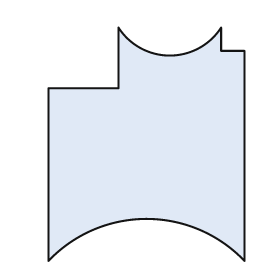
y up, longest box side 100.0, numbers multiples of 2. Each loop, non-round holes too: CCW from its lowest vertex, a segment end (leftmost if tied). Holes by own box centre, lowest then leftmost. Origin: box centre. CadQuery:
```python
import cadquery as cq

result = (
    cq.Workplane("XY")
    .moveTo(-42.0, -50.0)
    .threePointArc((0.0, -32.0), (42.0, -50.0))
    .lineTo(42.0, 40.0)
    .lineTo(32.0, 40.0)
    .lineTo(32.0, 50.0)
    .threePointArc((10.0, 38.0), (-12.0, 50.0))
    .lineTo(-12.0, 24.0)
    .lineTo(-42.0, 24.0)
    .close()
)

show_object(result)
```